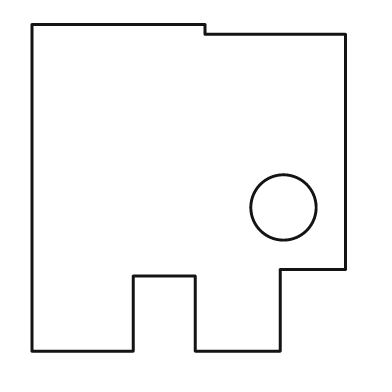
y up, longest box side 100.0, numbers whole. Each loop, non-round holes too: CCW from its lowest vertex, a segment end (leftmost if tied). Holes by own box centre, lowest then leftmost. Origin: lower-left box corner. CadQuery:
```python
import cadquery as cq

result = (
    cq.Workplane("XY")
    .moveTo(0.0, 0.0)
    .lineTo(31.0, 0.0)
    .lineTo(31.0, 23.0)
    .lineTo(50.0, 23.0)
    .lineTo(50.0, 0.0)
    .lineTo(76.0, 0.0)
    .lineTo(76.0, 25.0)
    .lineTo(96.0, 25.0)
    .lineTo(96.0, 97.0)
    .lineTo(53.0, 97.0)
    .lineTo(53.0, 100.0)
    .lineTo(0.0, 100.0)
    .close()
    .moveTo(77.0, 44.0)
    .circle(10.0)
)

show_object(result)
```